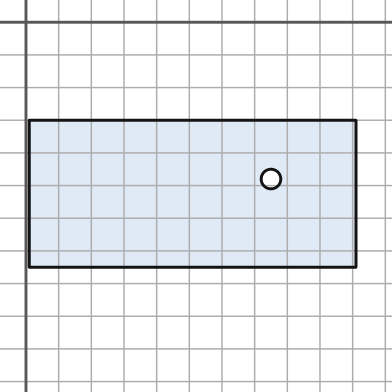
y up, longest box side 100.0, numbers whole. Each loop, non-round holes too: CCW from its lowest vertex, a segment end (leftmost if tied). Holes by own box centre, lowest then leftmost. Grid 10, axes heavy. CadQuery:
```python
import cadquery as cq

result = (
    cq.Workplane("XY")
    .moveTo(1.0, -75.0)
    .lineTo(101.0, -75.0)
    .lineTo(101.0, -30.0)
    .lineTo(1.0, -30.0)
    .close()
    .moveTo(75.0, -48.0)
    .circle(3.0)
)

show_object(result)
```